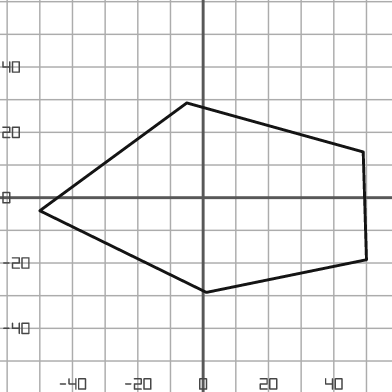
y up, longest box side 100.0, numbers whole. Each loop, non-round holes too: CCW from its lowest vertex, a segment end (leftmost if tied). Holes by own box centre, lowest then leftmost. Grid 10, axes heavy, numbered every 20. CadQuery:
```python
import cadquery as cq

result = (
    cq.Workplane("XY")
    .moveTo(1.0, -29.0)
    .lineTo(50.0, -19.0)
    .lineTo(49.0, 14.0)
    .lineTo(-5.0, 29.0)
    .lineTo(-50.0, -4.0)
    .close()
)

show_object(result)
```